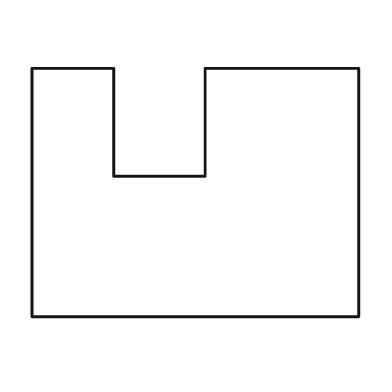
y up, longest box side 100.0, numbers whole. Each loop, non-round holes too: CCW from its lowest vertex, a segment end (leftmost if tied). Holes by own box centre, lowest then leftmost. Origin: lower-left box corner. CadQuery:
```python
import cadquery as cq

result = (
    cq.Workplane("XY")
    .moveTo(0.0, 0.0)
    .lineTo(100.0, 0.0)
    .lineTo(100.0, 76.0)
    .lineTo(53.0, 76.0)
    .lineTo(53.0, 43.0)
    .lineTo(25.0, 43.0)
    .lineTo(25.0, 76.0)
    .lineTo(0.0, 76.0)
    .close()
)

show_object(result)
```